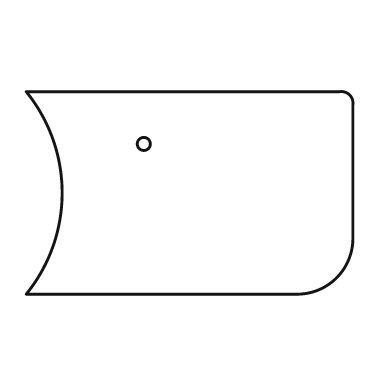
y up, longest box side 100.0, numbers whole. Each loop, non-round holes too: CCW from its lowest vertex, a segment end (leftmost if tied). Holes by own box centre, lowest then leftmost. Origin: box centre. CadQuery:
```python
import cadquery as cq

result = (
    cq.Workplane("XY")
    .moveTo(-50.0, -31.0)
    .lineTo(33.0, -31.0)
    .threePointArc((45.0, -26.0), (50.0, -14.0))
    .lineTo(50.0, 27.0)
    .threePointArc((49.0, 30.0), (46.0, 31.0))
    .lineTo(-50.0, 31.0)
    .threePointArc((-39.0, 0.0), (-50.0, -31.0))
    .close()
    .moveTo(-14.0, 15.0)
    .circle(2.0)
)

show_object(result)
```